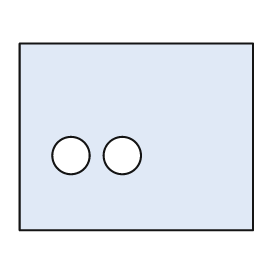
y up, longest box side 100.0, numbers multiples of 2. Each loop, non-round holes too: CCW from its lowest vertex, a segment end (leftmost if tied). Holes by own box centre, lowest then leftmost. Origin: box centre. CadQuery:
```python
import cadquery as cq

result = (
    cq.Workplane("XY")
    .moveTo(-50.0, -40.0)
    .lineTo(50.0, -40.0)
    .lineTo(50.0, 40.0)
    .lineTo(-50.0, 40.0)
    .close()
    .moveTo(-28.0, -8.0)
    .circle(8.0)
    .moveTo(-6.0, -8.0)
    .circle(8.0)
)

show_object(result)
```